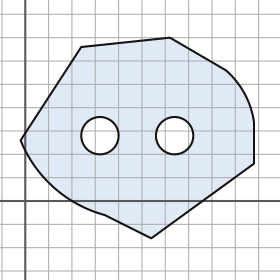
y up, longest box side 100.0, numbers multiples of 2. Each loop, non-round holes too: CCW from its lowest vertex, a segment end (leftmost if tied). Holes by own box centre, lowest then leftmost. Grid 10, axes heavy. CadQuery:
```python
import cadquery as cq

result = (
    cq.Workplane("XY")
    .moveTo(54.0, -16.0)
    .lineTo(98.0, 16.0)
    .lineTo(98.0, 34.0)
    .threePointArc((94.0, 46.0), (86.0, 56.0))
    .lineTo(62.0, 70.0)
    .lineTo(24.0, 66.0)
    .lineTo(-2.0, 26.0)
    .threePointArc((12.0, 6.0), (34.0, -6.0))
    .close()
    .moveTo(32.0, 28.0)
    .circle(8.0)
    .moveTo(64.0, 28.0)
    .circle(8.0)
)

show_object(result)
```